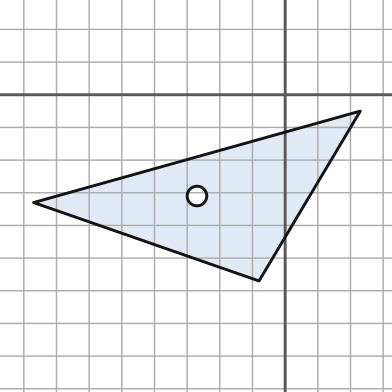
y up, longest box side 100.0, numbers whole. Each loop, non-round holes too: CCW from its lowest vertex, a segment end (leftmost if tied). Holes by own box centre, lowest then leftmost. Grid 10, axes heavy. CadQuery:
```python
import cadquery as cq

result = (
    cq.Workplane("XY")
    .moveTo(-8.0, -57.0)
    .lineTo(23.0, -5.0)
    .lineTo(-77.0, -33.0)
    .close()
    .moveTo(-27.0, -31.0)
    .circle(3.0)
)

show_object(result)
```